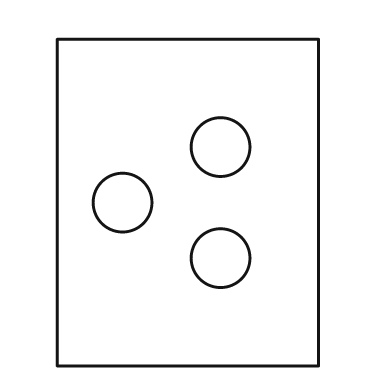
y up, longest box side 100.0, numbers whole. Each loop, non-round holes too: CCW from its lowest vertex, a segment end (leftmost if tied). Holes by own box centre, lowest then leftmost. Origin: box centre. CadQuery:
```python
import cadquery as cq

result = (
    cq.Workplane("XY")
    .moveTo(-40.0, -50.0)
    .lineTo(40.0, -50.0)
    .lineTo(40.0, 50.0)
    .lineTo(-40.0, 50.0)
    .close()
    .moveTo(10.0, -17.0)
    .circle(9.0)
    .moveTo(-20.0, 0.0)
    .circle(9.0)
    .moveTo(10.0, 17.0)
    .circle(9.0)
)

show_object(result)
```